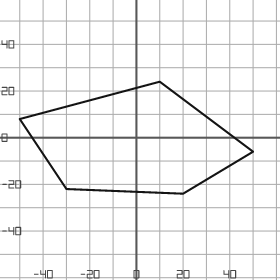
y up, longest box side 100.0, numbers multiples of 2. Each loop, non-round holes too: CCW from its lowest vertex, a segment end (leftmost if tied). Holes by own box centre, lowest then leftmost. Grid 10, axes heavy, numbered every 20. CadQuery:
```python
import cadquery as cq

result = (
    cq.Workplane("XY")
    .moveTo(20.0, -24.0)
    .lineTo(50.0, -6.0)
    .lineTo(10.0, 24.0)
    .lineTo(-50.0, 8.0)
    .lineTo(-30.0, -22.0)
    .close()
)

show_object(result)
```